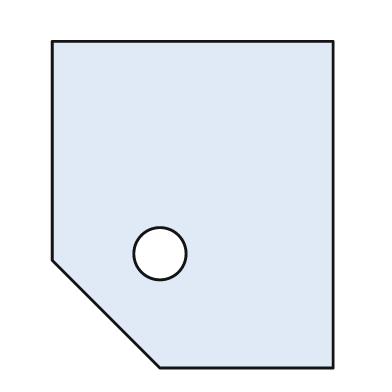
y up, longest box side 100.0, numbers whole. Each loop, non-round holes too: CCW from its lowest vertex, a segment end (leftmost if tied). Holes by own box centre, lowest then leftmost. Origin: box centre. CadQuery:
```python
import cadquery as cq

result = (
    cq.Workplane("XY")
    .moveTo(-10.0, -50.0)
    .lineTo(43.0, -50.0)
    .lineTo(43.0, 50.0)
    .lineTo(-43.0, 50.0)
    .lineTo(-43.0, -17.0)
    .close()
    .moveTo(-10.0, -15.0)
    .circle(8.0)
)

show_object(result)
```